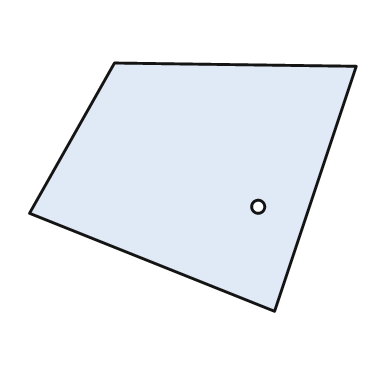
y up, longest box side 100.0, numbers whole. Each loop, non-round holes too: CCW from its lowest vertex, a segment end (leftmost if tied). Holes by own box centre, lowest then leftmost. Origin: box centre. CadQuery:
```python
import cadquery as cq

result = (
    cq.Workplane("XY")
    .moveTo(25.0, -38.0)
    .lineTo(50.0, 37.0)
    .lineTo(-24.0, 38.0)
    .lineTo(-50.0, -8.0)
    .close()
    .moveTo(20.0, -6.0)
    .circle(2.0)
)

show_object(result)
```